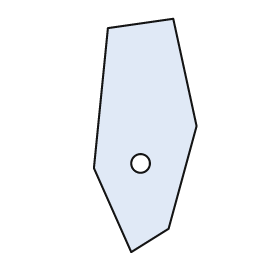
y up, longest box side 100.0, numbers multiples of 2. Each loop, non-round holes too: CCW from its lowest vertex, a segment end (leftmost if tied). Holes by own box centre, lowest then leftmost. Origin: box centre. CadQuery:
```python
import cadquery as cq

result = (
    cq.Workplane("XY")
    .moveTo(-6.0, -50.0)
    .lineTo(10.0, -40.0)
    .lineTo(22.0, 4.0)
    .lineTo(12.0, 50.0)
    .lineTo(-16.0, 46.0)
    .lineTo(-22.0, -14.0)
    .close()
    .moveTo(-2.0, -12.0)
    .circle(4.0)
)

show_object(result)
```